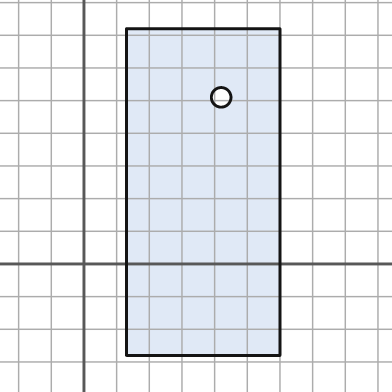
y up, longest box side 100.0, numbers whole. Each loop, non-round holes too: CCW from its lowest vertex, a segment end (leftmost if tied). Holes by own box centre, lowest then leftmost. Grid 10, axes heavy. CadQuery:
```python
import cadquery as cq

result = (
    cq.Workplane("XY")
    .moveTo(13.0, -28.0)
    .lineTo(60.0, -28.0)
    .lineTo(60.0, 72.0)
    .lineTo(13.0, 72.0)
    .close()
    .moveTo(42.0, 51.0)
    .circle(3.0)
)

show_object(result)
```